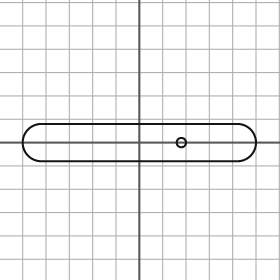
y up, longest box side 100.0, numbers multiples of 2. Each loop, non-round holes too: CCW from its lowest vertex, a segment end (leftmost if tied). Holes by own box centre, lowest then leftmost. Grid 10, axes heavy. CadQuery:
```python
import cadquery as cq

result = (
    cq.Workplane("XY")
    .moveTo(-42.0, -8.0)
    .lineTo(42.0, -8.0)
    .threePointArc((50.0, 0.0), (42.0, 8.0))
    .lineTo(-42.0, 8.0)
    .threePointArc((-50.0, 0.0), (-42.0, -8.0))
    .close()
    .moveTo(18.0, 0.0)
    .circle(2.0)
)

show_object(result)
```